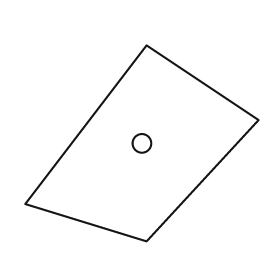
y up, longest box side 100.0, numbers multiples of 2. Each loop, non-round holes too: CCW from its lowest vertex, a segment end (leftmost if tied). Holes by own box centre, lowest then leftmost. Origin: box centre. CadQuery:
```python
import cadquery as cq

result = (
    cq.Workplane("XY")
    .moveTo(2.0, -42.0)
    .lineTo(50.0, 10.0)
    .lineTo(2.0, 42.0)
    .lineTo(-50.0, -26.0)
    .close()
    .moveTo(0.0, 0.0)
    .circle(4.0)
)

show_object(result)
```